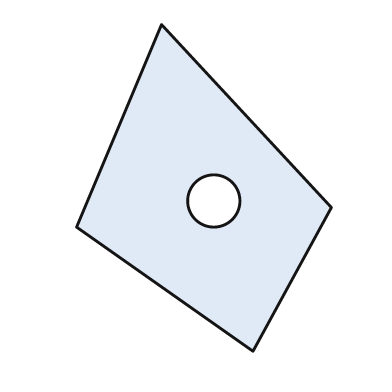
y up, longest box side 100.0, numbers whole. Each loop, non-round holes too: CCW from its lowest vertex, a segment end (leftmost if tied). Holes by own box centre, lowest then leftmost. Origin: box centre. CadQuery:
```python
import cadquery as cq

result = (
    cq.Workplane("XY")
    .moveTo(15.0, -50.0)
    .lineTo(39.0, -6.0)
    .lineTo(-13.0, 50.0)
    .lineTo(-39.0, -12.0)
    .close()
    .moveTo(3.0, -4.0)
    .circle(8.0)
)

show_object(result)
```